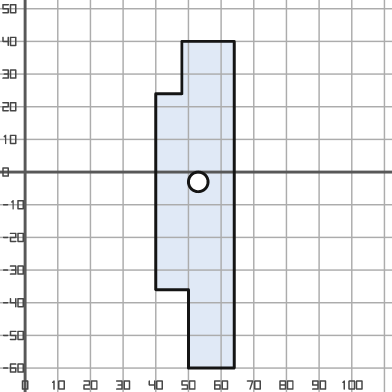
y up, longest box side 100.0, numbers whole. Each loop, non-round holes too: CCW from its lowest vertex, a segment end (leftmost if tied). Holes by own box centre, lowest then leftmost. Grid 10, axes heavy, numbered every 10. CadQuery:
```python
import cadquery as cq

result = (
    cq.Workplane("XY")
    .moveTo(50.0, -60.0)
    .lineTo(64.0, -60.0)
    .lineTo(64.0, 40.0)
    .lineTo(48.0, 40.0)
    .lineTo(48.0, 24.0)
    .lineTo(40.0, 24.0)
    .lineTo(40.0, -36.0)
    .lineTo(50.0, -36.0)
    .close()
    .moveTo(53.0, -3.0)
    .circle(3.0)
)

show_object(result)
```